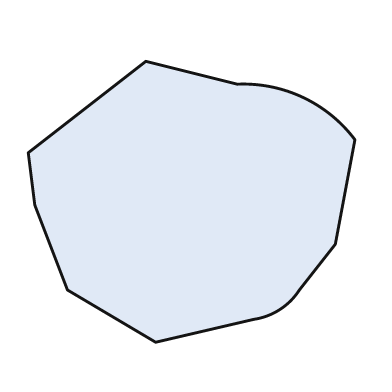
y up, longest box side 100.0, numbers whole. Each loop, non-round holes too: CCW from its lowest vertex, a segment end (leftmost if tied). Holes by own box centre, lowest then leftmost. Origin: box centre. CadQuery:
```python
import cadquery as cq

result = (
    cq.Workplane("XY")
    .moveTo(-11.0, -43.0)
    .lineTo(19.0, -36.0)
    .threePointArc((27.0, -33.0), (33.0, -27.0))
    .lineTo(44.0, -13.0)
    .lineTo(50.0, 19.0)
    .threePointArc((34.0, 32.0), (14.0, 36.0))
    .lineTo(-14.0, 43.0)
    .lineTo(-50.0, 15.0)
    .lineTo(-48.0, -1.0)
    .lineTo(-38.0, -27.0)
    .close()
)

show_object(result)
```